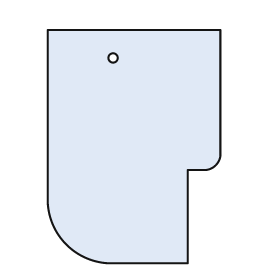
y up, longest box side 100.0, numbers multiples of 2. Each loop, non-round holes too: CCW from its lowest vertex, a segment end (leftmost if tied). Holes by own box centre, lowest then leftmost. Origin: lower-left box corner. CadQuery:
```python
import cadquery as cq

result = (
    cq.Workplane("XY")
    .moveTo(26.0, 0.0)
    .lineTo(60.0, 0.0)
    .lineTo(60.0, 40.0)
    .lineTo(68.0, 40.0)
    .threePointArc((72.0, 42.0), (74.0, 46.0))
    .lineTo(74.0, 100.0)
    .lineTo(0.0, 100.0)
    .lineTo(0.0, 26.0)
    .threePointArc((8.0, 8.0), (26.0, 0.0))
    .close()
    .moveTo(28.0, 88.0)
    .circle(2.0)
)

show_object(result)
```